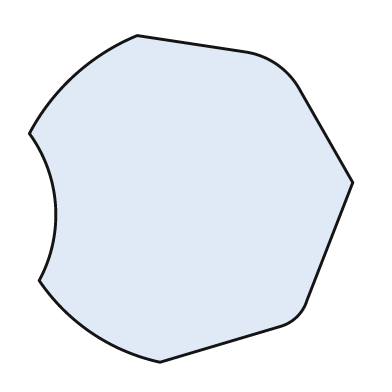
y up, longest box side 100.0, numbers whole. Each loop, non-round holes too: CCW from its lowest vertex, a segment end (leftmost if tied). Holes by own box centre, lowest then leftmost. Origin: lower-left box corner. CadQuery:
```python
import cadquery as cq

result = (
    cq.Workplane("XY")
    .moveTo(40.0, 0.0)
    .lineTo(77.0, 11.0)
    .threePointArc((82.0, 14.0), (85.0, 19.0))
    .lineTo(99.0, 55.0)
    .lineTo(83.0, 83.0)
    .threePointArc((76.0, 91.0), (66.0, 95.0))
    .lineTo(33.0, 100.0)
    .threePointArc((14.0, 88.0), (0.0, 70.0))
    .threePointArc((8.0, 48.0), (3.0, 25.0))
    .threePointArc((19.0, 9.0), (40.0, 0.0))
    .close()
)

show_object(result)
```